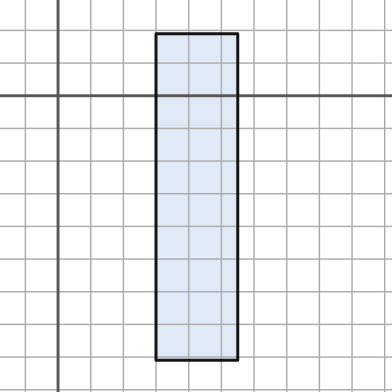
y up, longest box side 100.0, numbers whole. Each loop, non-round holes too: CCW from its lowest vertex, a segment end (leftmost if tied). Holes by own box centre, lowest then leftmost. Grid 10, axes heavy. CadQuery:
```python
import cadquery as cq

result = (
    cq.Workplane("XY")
    .moveTo(30.0, -81.0)
    .lineTo(55.0, -81.0)
    .lineTo(55.0, 19.0)
    .lineTo(30.0, 19.0)
    .close()
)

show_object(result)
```